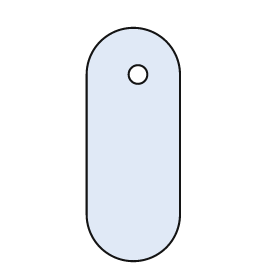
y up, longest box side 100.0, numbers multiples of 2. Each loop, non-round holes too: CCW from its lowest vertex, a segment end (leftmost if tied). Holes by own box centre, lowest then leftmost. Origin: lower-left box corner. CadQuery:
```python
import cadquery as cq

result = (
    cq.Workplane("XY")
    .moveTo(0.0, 20.0)
    .threePointArc((20.0, 0.0), (40.0, 20.0))
    .lineTo(40.0, 80.0)
    .threePointArc((20.0, 100.0), (0.0, 80.0))
    .close()
    .moveTo(22.0, 80.0)
    .circle(4.0)
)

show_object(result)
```